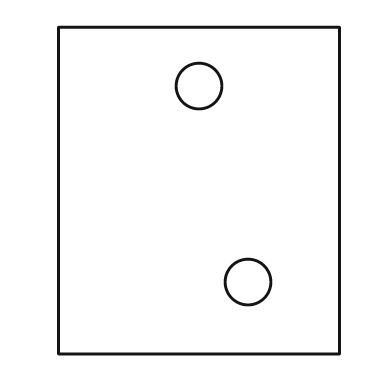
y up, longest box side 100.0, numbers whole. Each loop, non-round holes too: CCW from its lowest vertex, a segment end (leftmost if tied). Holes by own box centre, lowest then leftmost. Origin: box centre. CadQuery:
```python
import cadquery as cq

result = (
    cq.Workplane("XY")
    .moveTo(-43.0, -50.0)
    .lineTo(43.0, -50.0)
    .lineTo(43.0, 50.0)
    .lineTo(-43.0, 50.0)
    .close()
    .moveTo(15.0, -28.0)
    .circle(7.0)
    .moveTo(0.0, 32.0)
    .circle(7.0)
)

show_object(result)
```